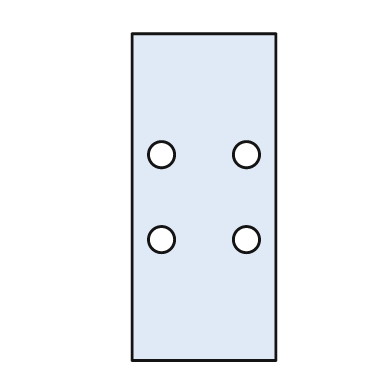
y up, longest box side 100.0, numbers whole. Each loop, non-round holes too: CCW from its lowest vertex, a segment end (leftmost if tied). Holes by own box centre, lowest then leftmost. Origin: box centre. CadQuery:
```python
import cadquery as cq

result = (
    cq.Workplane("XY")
    .moveTo(-22.0, -50.0)
    .lineTo(22.0, -50.0)
    .lineTo(22.0, 50.0)
    .lineTo(-22.0, 50.0)
    .close()
    .moveTo(-13.0, -13.0)
    .circle(4.0)
    .moveTo(13.0, -13.0)
    .circle(4.0)
    .moveTo(-13.0, 13.0)
    .circle(4.0)
    .moveTo(13.0, 13.0)
    .circle(4.0)
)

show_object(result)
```